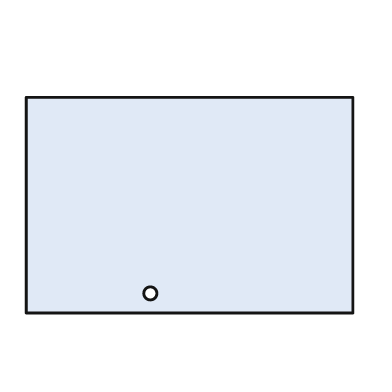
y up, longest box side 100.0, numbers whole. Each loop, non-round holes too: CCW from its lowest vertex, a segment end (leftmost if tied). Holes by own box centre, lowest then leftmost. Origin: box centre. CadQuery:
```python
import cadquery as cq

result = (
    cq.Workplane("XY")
    .moveTo(-50.0, -33.0)
    .lineTo(50.0, -33.0)
    .lineTo(50.0, 33.0)
    .lineTo(-50.0, 33.0)
    .close()
    .moveTo(-12.0, -27.0)
    .circle(2.0)
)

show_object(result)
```